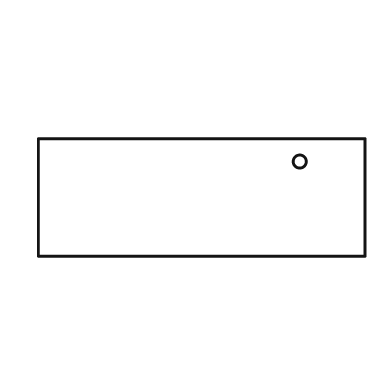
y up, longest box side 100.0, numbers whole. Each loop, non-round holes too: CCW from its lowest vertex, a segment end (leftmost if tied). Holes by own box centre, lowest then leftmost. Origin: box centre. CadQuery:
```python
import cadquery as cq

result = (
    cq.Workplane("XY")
    .moveTo(-50.0, -18.0)
    .lineTo(50.0, -18.0)
    .lineTo(50.0, 18.0)
    .lineTo(-50.0, 18.0)
    .close()
    .moveTo(30.0, 11.0)
    .circle(2.0)
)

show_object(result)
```